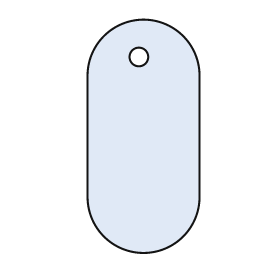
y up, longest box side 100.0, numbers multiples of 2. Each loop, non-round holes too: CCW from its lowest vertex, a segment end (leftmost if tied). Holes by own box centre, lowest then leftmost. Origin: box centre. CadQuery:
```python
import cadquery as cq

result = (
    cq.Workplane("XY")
    .moveTo(-24.0, -26.0)
    .threePointArc((0.0, -50.0), (24.0, -26.0))
    .lineTo(24.0, 26.0)
    .threePointArc((0.0, 50.0), (-24.0, 26.0))
    .close()
    .moveTo(-2.0, 34.0)
    .circle(4.0)
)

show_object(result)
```